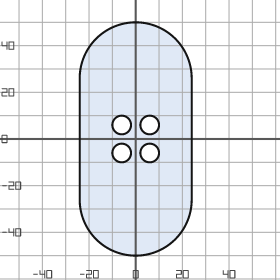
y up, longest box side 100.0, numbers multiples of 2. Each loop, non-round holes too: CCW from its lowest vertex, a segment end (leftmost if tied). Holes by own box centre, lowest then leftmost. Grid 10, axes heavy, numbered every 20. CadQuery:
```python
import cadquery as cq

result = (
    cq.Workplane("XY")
    .moveTo(-24.0, -26.0)
    .threePointArc((0.0, -50.0), (24.0, -26.0))
    .lineTo(24.0, 26.0)
    .threePointArc((0.0, 50.0), (-24.0, 26.0))
    .close()
    .moveTo(-6.0, -6.0)
    .circle(4.0)
    .moveTo(6.0, -6.0)
    .circle(4.0)
    .moveTo(-6.0, 6.0)
    .circle(4.0)
    .moveTo(6.0, 6.0)
    .circle(4.0)
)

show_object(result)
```